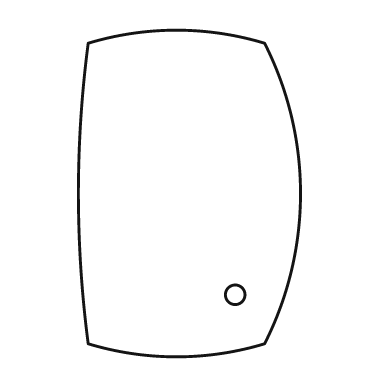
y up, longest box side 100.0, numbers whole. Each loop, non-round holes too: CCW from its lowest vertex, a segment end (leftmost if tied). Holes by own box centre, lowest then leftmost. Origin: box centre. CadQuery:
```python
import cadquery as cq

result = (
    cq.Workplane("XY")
    .moveTo(-31.0, -46.0)
    .threePointArc((-4.0, -50.0), (23.0, -46.0))
    .threePointArc((34.0, 0.0), (23.0, 46.0))
    .threePointArc((-4.0, 50.0), (-31.0, 46.0))
    .threePointArc((-34.0, 0.0), (-31.0, -46.0))
    .close()
    .moveTo(14.0, -31.0)
    .circle(3.0)
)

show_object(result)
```